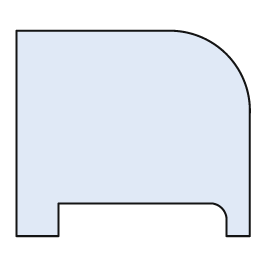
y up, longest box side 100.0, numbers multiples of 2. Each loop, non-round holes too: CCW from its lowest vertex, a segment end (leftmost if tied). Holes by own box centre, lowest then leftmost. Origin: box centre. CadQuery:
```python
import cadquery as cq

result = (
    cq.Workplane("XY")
    .moveTo(-50.0, -44.0)
    .lineTo(-32.0, -44.0)
    .lineTo(-32.0, -30.0)
    .lineTo(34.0, -30.0)
    .threePointArc((38.0, -32.0), (40.0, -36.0))
    .lineTo(40.0, -44.0)
    .lineTo(50.0, -44.0)
    .lineTo(50.0, 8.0)
    .threePointArc((40.0, 34.0), (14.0, 44.0))
    .lineTo(-50.0, 44.0)
    .close()
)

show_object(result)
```